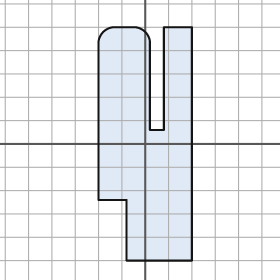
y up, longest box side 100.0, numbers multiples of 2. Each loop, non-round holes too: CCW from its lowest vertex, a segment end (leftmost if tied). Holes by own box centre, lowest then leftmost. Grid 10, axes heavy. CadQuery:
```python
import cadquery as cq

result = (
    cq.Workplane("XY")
    .moveTo(-8.0, -50.0)
    .lineTo(20.0, -50.0)
    .lineTo(20.0, 50.0)
    .lineTo(8.0, 50.0)
    .lineTo(8.0, 6.0)
    .lineTo(2.0, 6.0)
    .lineTo(2.0, 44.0)
    .threePointArc((0.0, 48.0), (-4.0, 50.0))
    .lineTo(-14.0, 50.0)
    .threePointArc((-18.0, 48.0), (-20.0, 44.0))
    .lineTo(-20.0, -24.0)
    .lineTo(-8.0, -24.0)
    .close()
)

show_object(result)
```